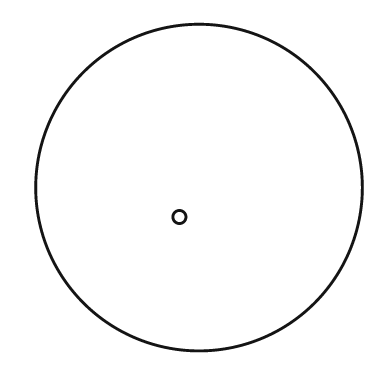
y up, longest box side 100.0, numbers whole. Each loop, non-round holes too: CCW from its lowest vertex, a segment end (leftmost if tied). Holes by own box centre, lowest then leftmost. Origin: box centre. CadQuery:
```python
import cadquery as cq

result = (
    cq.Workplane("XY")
    .moveTo(0.0, 0.0)
    .circle(50.0)
    .moveTo(-6.0, -9.0)
    .circle(2.0)
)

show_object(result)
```